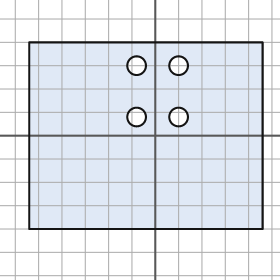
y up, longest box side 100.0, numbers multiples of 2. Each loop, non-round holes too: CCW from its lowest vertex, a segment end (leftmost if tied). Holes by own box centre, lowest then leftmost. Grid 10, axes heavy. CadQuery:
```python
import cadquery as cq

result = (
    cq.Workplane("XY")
    .moveTo(-54.0, -40.0)
    .lineTo(46.0, -40.0)
    .lineTo(46.0, 40.0)
    .lineTo(-54.0, 40.0)
    .close()
    .moveTo(-8.0, 8.0)
    .circle(4.0)
    .moveTo(10.0, 8.0)
    .circle(4.0)
    .moveTo(-8.0, 30.0)
    .circle(4.0)
    .moveTo(10.0, 30.0)
    .circle(4.0)
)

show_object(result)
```